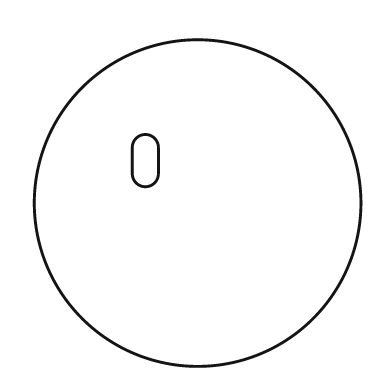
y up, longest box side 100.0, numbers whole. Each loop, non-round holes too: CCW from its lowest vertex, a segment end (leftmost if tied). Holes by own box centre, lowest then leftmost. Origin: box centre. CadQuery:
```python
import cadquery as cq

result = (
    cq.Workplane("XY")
    .moveTo(0.0, 0.0)
    .circle(50.0)
    .moveTo(-20.0, 9.0)
    .threePointArc((-16.0, 5.0), (-12.0, 9.0))
    .lineTo(-12.0, 17.0)
    .threePointArc((-16.0, 21.0), (-20.0, 17.0))
    .close()
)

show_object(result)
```